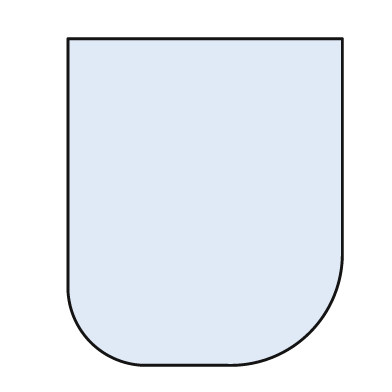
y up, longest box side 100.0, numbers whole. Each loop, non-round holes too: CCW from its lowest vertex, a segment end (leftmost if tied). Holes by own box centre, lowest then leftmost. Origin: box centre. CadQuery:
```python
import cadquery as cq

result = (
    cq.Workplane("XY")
    .moveTo(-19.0, -50.0)
    .lineTo(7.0, -50.0)
    .threePointArc((32.0, -40.0), (42.0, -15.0))
    .lineTo(42.0, 50.0)
    .lineTo(-42.0, 50.0)
    .lineTo(-42.0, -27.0)
    .threePointArc((-35.0, -43.0), (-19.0, -50.0))
    .close()
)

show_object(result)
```